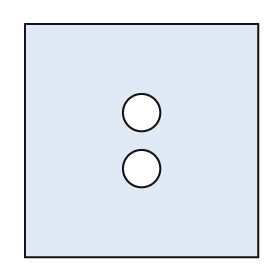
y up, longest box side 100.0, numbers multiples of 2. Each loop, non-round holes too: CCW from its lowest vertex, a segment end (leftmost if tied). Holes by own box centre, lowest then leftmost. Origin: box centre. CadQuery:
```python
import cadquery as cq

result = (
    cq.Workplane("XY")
    .moveTo(-50.0, -50.0)
    .lineTo(50.0, -50.0)
    .lineTo(50.0, 50.0)
    .lineTo(-50.0, 50.0)
    .close()
    .moveTo(0.0, -12.0)
    .circle(8.0)
    .moveTo(0.0, 12.0)
    .circle(8.0)
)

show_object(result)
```